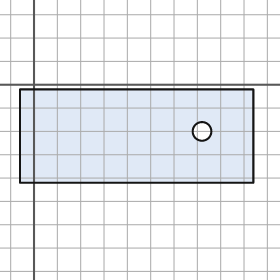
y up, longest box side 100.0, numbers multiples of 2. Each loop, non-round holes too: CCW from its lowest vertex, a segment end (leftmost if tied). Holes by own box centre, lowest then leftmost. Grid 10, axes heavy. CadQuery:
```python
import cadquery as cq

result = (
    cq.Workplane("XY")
    .moveTo(-6.0, -42.0)
    .lineTo(94.0, -42.0)
    .lineTo(94.0, -2.0)
    .lineTo(-6.0, -2.0)
    .close()
    .moveTo(72.0, -20.0)
    .circle(4.0)
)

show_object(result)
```